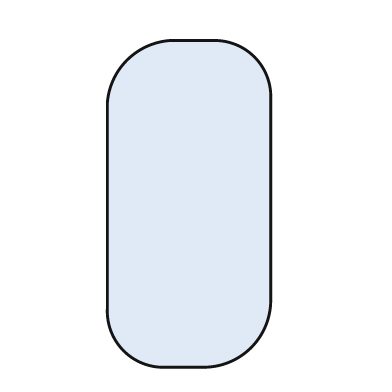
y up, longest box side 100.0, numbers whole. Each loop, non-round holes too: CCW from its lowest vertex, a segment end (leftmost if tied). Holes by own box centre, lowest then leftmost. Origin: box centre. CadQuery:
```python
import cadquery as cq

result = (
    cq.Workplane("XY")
    .moveTo(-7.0, -50.0)
    .lineTo(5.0, -50.0)
    .threePointArc((19.0, -44.0), (25.0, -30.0))
    .lineTo(25.0, 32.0)
    .threePointArc((20.0, 45.0), (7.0, 50.0))
    .lineTo(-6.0, 50.0)
    .threePointArc((-19.0, 44.0), (-25.0, 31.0))
    .lineTo(-25.0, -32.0)
    .threePointArc((-20.0, -45.0), (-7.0, -50.0))
    .close()
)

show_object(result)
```